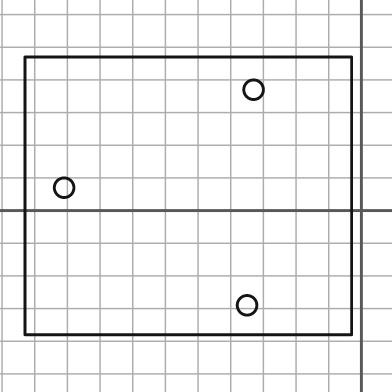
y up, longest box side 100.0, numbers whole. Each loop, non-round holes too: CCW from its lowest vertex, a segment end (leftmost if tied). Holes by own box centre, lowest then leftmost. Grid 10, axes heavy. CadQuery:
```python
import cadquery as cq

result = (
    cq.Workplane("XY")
    .moveTo(-103.0, -38.0)
    .lineTo(-3.0, -38.0)
    .lineTo(-3.0, 47.0)
    .lineTo(-103.0, 47.0)
    .close()
    .moveTo(-35.0, -29.0)
    .circle(3.0)
    .moveTo(-91.0, 7.0)
    .circle(3.0)
    .moveTo(-33.0, 37.0)
    .circle(3.0)
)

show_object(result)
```